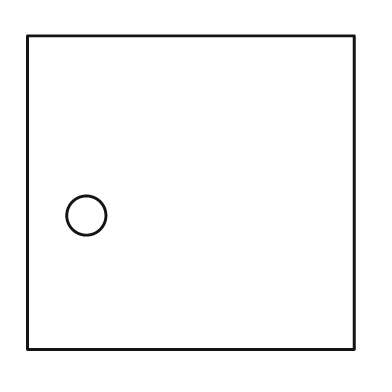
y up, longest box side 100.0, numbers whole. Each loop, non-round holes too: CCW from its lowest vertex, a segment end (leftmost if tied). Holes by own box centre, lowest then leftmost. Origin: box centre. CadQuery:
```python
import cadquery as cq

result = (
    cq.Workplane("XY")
    .moveTo(-50.0, -48.0)
    .lineTo(50.0, -48.0)
    .lineTo(50.0, 48.0)
    .lineTo(-50.0, 48.0)
    .close()
    .moveTo(-32.0, -7.0)
    .circle(6.0)
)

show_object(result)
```